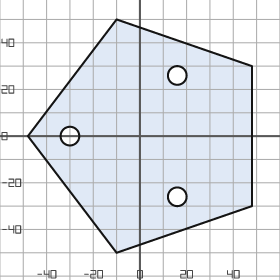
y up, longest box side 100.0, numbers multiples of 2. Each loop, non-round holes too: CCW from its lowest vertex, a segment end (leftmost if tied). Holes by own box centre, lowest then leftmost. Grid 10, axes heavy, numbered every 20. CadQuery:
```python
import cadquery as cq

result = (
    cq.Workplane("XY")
    .moveTo(-10.0, -50.0)
    .lineTo(48.0, -30.0)
    .lineTo(48.0, 30.0)
    .lineTo(-10.0, 50.0)
    .lineTo(-48.0, 0.0)
    .close()
    .moveTo(16.0, -26.0)
    .circle(4.0)
    .moveTo(-30.0, 0.0)
    .circle(4.0)
    .moveTo(16.0, 26.0)
    .circle(4.0)
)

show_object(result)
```